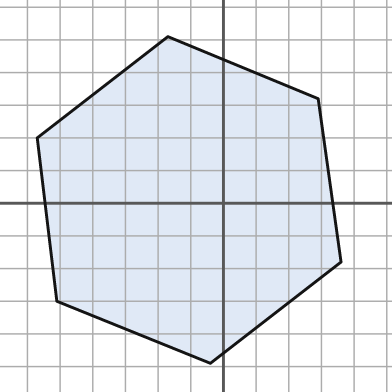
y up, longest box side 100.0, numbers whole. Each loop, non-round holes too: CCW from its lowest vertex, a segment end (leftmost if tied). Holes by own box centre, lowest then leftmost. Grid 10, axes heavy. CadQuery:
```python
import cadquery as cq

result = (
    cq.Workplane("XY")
    .moveTo(-4.0, -49.0)
    .lineTo(36.0, -18.0)
    .lineTo(29.0, 32.0)
    .lineTo(-17.0, 51.0)
    .lineTo(-57.0, 20.0)
    .lineTo(-51.0, -30.0)
    .close()
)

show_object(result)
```